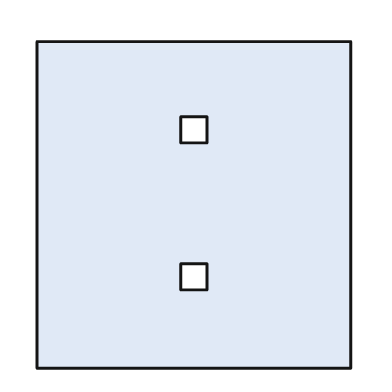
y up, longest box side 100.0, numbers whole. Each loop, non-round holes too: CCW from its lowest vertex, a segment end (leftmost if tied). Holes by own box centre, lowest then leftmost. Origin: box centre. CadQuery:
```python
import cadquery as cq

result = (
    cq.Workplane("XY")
    .moveTo(-48.0, -50.0)
    .lineTo(48.0, -50.0)
    .lineTo(48.0, 50.0)
    .lineTo(-48.0, 50.0)
    .close()
    .moveTo(-4.0, -26.0)
    .lineTo(4.0, -26.0)
    .lineTo(4.0, -18.0)
    .lineTo(-4.0, -18.0)
    .close()
    .moveTo(-4.0, 19.0)
    .lineTo(4.0, 19.0)
    .lineTo(4.0, 27.0)
    .lineTo(-4.0, 27.0)
    .close()
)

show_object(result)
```